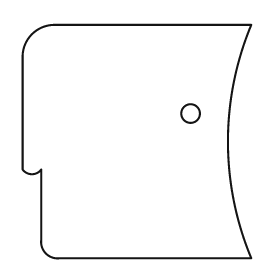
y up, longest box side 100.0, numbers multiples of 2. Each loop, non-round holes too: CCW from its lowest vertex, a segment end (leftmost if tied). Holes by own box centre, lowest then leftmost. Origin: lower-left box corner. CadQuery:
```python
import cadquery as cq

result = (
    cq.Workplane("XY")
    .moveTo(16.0, 0.0)
    .lineTo(98.0, 0.0)
    .threePointArc((88.0, 50.0), (98.0, 100.0))
    .lineTo(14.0, 100.0)
    .threePointArc((4.0, 96.0), (0.0, 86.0))
    .lineTo(0.0, 38.0)
    .threePointArc((4.0, 36.0), (8.0, 38.0))
    .lineTo(8.0, 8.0)
    .threePointArc((10.0, 2.0), (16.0, 0.0))
    .close()
    .moveTo(72.0, 62.0)
    .circle(4.0)
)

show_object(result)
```